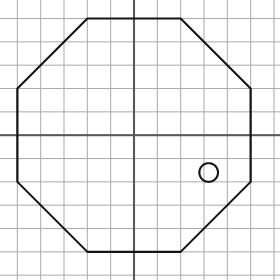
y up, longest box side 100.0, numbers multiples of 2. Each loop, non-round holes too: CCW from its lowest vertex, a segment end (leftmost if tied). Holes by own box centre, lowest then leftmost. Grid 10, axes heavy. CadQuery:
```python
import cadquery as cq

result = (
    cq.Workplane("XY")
    .moveTo(-20.0, -50.0)
    .lineTo(20.0, -50.0)
    .lineTo(50.0, -20.0)
    .lineTo(50.0, 20.0)
    .lineTo(20.0, 50.0)
    .lineTo(-20.0, 50.0)
    .lineTo(-50.0, 20.0)
    .lineTo(-50.0, -20.0)
    .close()
    .moveTo(32.0, -16.0)
    .circle(4.0)
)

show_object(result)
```